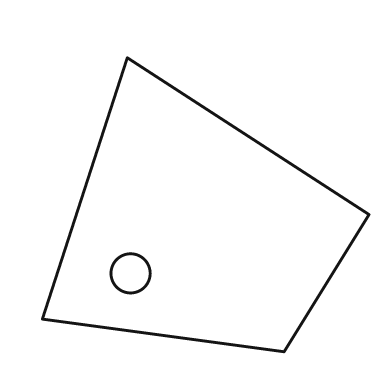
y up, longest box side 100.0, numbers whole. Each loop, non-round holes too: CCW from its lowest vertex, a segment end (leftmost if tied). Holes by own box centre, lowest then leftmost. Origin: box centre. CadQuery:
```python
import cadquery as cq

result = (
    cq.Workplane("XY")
    .moveTo(24.0, -45.0)
    .lineTo(50.0, -3.0)
    .lineTo(-24.0, 45.0)
    .lineTo(-50.0, -35.0)
    .close()
    .moveTo(-23.0, -21.0)
    .circle(6.0)
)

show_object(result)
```